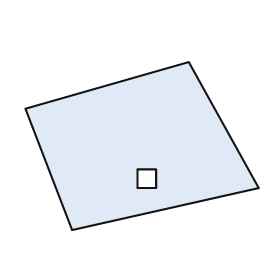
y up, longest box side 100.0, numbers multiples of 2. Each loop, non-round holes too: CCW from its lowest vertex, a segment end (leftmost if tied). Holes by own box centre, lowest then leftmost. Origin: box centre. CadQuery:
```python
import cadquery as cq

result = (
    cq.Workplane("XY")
    .moveTo(-30.0, -36.0)
    .lineTo(50.0, -18.0)
    .lineTo(20.0, 36.0)
    .lineTo(-50.0, 16.0)
    .close()
    .moveTo(-2.0, -18.0)
    .lineTo(6.0, -18.0)
    .lineTo(6.0, -10.0)
    .lineTo(-2.0, -10.0)
    .close()
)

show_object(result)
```